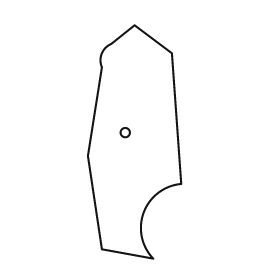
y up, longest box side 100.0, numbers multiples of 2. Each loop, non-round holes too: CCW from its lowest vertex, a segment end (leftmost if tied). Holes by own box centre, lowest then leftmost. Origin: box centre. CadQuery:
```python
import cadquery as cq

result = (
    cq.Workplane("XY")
    .moveTo(8.0, -50.0)
    .threePointArc((4.0, -30.0), (20.0, -18.0))
    .lineTo(16.0, 38.0)
    .lineTo(0.0, 50.0)
    .lineTo(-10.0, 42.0)
    .threePointArc((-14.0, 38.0), (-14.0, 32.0))
    .lineTo(-20.0, -6.0)
    .lineTo(-14.0, -46.0)
    .close()
    .moveTo(-4.0, 4.0)
    .circle(2.0)
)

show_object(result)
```